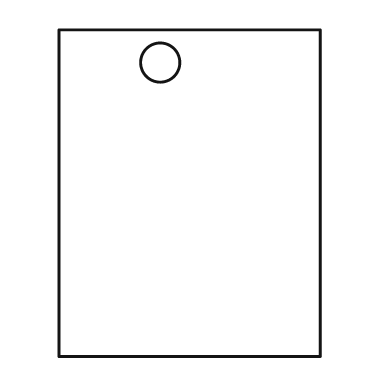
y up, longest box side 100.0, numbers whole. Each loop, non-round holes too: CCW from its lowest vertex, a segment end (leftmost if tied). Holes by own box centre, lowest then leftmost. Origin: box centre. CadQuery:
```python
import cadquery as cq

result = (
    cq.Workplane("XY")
    .moveTo(-40.0, -50.0)
    .lineTo(40.0, -50.0)
    .lineTo(40.0, 50.0)
    .lineTo(-40.0, 50.0)
    .close()
    .moveTo(-9.0, 40.0)
    .circle(6.0)
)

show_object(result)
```